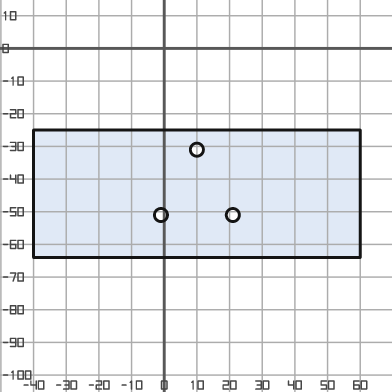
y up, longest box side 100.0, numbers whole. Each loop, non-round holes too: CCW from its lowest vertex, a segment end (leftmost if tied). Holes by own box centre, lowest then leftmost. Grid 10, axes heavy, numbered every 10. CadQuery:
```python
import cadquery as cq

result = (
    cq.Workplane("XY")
    .moveTo(-40.0, -64.0)
    .lineTo(60.0, -64.0)
    .lineTo(60.0, -25.0)
    .lineTo(-40.0, -25.0)
    .close()
    .moveTo(-1.0, -51.0)
    .circle(2.0)
    .moveTo(21.0, -51.0)
    .circle(2.0)
    .moveTo(10.0, -31.0)
    .circle(2.0)
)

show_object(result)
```